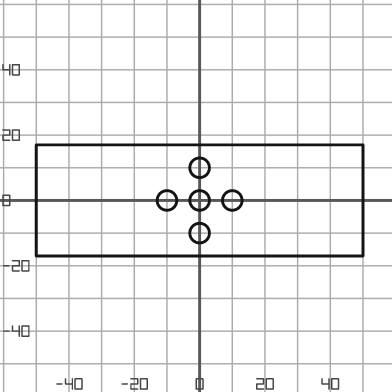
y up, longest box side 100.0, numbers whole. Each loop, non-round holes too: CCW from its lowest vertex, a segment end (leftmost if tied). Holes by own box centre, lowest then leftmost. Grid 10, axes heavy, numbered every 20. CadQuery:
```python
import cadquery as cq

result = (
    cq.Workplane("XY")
    .moveTo(-50.0, -17.0)
    .lineTo(50.0, -17.0)
    .lineTo(50.0, 17.0)
    .lineTo(-50.0, 17.0)
    .close()
    .moveTo(0.0, -10.0)
    .circle(3.0)
    .moveTo(-10.0, 0.0)
    .circle(3.0)
    .moveTo(0.0, 0.0)
    .circle(3.0)
    .moveTo(10.0, 0.0)
    .circle(3.0)
    .moveTo(0.0, 10.0)
    .circle(3.0)
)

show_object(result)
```